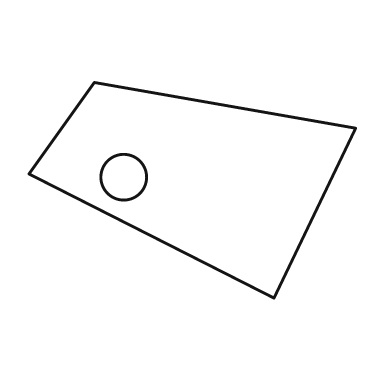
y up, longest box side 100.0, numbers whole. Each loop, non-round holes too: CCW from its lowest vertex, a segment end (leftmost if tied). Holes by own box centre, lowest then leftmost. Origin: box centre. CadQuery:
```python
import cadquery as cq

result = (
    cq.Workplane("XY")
    .moveTo(25.0, -33.0)
    .lineTo(50.0, 19.0)
    .lineTo(-30.0, 33.0)
    .lineTo(-50.0, 5.0)
    .close()
    .moveTo(-21.0, 4.0)
    .circle(7.0)
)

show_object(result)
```